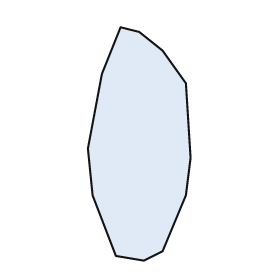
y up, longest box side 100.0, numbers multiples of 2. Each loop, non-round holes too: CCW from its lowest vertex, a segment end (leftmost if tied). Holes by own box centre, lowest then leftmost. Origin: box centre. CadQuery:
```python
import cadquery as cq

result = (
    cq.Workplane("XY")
    .moveTo(2.0, -50.0)
    .lineTo(10.0, -46.0)
    .lineTo(20.0, -22.0)
    .lineTo(22.0, -6.0)
    .lineTo(20.0, 26.0)
    .lineTo(10.0, 40.0)
    .lineTo(0.0, 48.0)
    .lineTo(-8.0, 50.0)
    .lineTo(-16.0, 30.0)
    .lineTo(-22.0, -2.0)
    .lineTo(-20.0, -22.0)
    .lineTo(-10.0, -48.0)
    .close()
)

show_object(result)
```